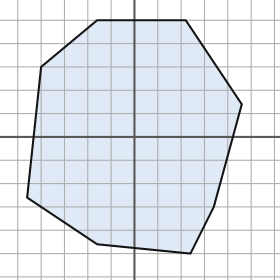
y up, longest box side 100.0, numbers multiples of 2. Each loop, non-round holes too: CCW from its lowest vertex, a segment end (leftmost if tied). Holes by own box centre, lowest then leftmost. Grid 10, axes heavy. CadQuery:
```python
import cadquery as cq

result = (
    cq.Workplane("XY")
    .moveTo(24.0, -50.0)
    .lineTo(34.0, -30.0)
    .lineTo(46.0, 14.0)
    .lineTo(22.0, 50.0)
    .lineTo(-16.0, 50.0)
    .lineTo(-40.0, 30.0)
    .lineTo(-46.0, -26.0)
    .lineTo(-16.0, -46.0)
    .close()
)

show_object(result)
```